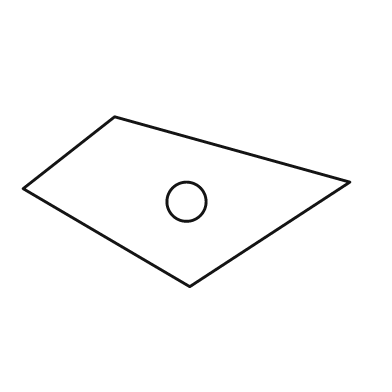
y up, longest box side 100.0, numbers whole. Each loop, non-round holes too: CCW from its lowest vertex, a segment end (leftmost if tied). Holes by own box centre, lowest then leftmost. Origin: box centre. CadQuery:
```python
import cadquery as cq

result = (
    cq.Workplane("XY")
    .moveTo(1.0, -26.0)
    .lineTo(50.0, 6.0)
    .lineTo(-22.0, 26.0)
    .lineTo(-50.0, 4.0)
    .close()
    .moveTo(0.0, 0.0)
    .circle(6.0)
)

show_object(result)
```